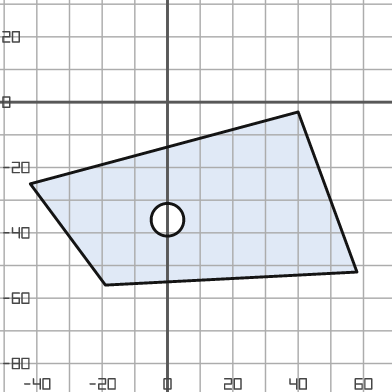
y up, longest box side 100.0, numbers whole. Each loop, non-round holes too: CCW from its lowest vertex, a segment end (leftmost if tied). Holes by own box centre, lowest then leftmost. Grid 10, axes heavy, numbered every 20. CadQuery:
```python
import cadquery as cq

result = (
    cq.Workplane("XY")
    .moveTo(-19.0, -56.0)
    .lineTo(58.0, -52.0)
    .lineTo(40.0, -3.0)
    .lineTo(-42.0, -25.0)
    .close()
    .moveTo(0.0, -36.0)
    .circle(5.0)
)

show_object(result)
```